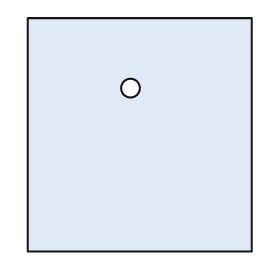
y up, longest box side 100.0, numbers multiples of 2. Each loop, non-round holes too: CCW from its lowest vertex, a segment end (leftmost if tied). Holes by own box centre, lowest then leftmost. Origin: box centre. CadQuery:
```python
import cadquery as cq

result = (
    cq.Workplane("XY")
    .moveTo(-48.0, -50.0)
    .lineTo(48.0, -50.0)
    .lineTo(48.0, 50.0)
    .lineTo(-48.0, 50.0)
    .close()
    .moveTo(-4.0, 20.0)
    .circle(4.0)
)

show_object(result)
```